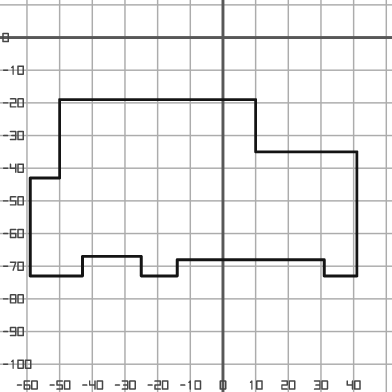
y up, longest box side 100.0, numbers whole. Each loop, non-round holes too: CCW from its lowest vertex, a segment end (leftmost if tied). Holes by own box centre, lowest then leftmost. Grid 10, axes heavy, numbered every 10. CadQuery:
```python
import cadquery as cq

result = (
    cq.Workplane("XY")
    .moveTo(-59.0, -73.0)
    .lineTo(-43.0, -73.0)
    .lineTo(-43.0, -67.0)
    .lineTo(-25.0, -67.0)
    .lineTo(-25.0, -73.0)
    .lineTo(-14.0, -73.0)
    .lineTo(-14.0, -68.0)
    .lineTo(31.0, -68.0)
    .lineTo(31.0, -73.0)
    .lineTo(41.0, -73.0)
    .lineTo(41.0, -35.0)
    .lineTo(10.0, -35.0)
    .lineTo(10.0, -19.0)
    .lineTo(-50.0, -19.0)
    .lineTo(-50.0, -43.0)
    .lineTo(-59.0, -43.0)
    .close()
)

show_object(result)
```